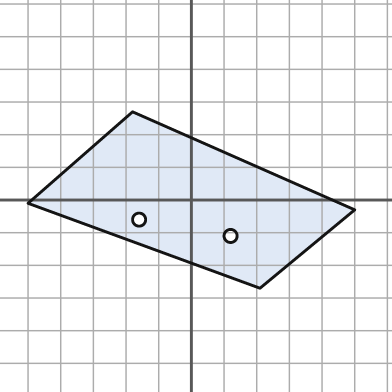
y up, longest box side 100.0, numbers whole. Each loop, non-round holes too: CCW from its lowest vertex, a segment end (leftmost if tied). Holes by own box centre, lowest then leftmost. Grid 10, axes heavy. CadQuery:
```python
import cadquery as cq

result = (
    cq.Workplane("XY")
    .moveTo(21.0, -27.0)
    .lineTo(50.0, -3.0)
    .lineTo(-18.0, 27.0)
    .lineTo(-50.0, -1.0)
    .close()
    .moveTo(12.0, -11.0)
    .circle(2.0)
    .moveTo(-16.0, -6.0)
    .circle(2.0)
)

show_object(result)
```